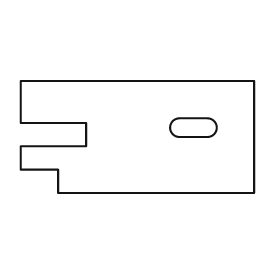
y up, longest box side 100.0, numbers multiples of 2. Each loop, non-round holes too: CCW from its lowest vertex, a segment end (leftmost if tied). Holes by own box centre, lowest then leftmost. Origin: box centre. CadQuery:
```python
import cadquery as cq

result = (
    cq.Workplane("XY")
    .moveTo(-34.0, -24.0)
    .lineTo(50.0, -24.0)
    .lineTo(50.0, 24.0)
    .lineTo(-50.0, 24.0)
    .lineTo(-50.0, 6.0)
    .lineTo(-22.0, 6.0)
    .lineTo(-22.0, -4.0)
    .lineTo(-50.0, -4.0)
    .lineTo(-50.0, -14.0)
    .lineTo(-34.0, -14.0)
    .close()
    .moveTo(18.0, 0.0)
    .lineTo(30.0, 0.0)
    .threePointArc((34.0, 4.0), (30.0, 8.0))
    .lineTo(18.0, 8.0)
    .threePointArc((14.0, 4.0), (18.0, 0.0))
    .close()
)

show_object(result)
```